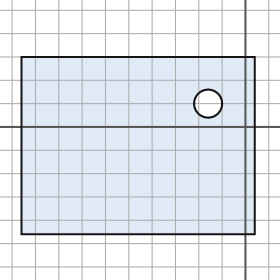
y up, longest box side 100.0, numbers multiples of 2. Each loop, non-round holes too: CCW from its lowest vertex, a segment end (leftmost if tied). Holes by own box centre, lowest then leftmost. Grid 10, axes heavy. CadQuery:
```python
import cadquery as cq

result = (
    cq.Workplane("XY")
    .moveTo(-96.0, -46.0)
    .lineTo(4.0, -46.0)
    .lineTo(4.0, 30.0)
    .lineTo(-96.0, 30.0)
    .close()
    .moveTo(-16.0, 10.0)
    .circle(6.0)
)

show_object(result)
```